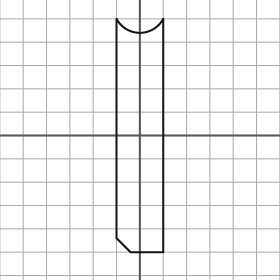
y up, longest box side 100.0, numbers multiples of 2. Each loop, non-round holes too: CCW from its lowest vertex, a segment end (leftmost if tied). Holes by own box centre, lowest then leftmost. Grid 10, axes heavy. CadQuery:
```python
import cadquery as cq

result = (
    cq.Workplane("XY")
    .moveTo(-4.0, -50.0)
    .lineTo(10.0, -50.0)
    .lineTo(10.0, 50.0)
    .threePointArc((0.0, 44.0), (-10.0, 50.0))
    .lineTo(-10.0, -44.0)
    .close()
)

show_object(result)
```